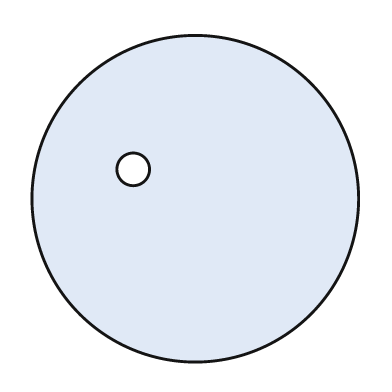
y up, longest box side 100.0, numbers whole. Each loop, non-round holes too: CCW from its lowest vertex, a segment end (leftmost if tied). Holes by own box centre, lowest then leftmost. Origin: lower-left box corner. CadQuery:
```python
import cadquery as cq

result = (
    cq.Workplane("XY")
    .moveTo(50.0, 50.0)
    .circle(50.0)
    .moveTo(31.0, 59.0)
    .circle(5.0)
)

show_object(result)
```